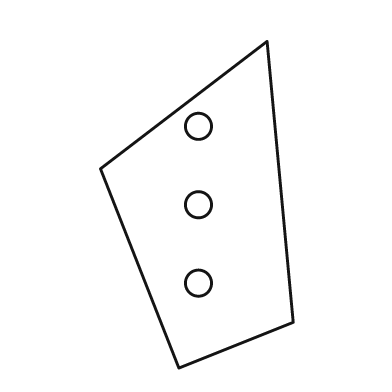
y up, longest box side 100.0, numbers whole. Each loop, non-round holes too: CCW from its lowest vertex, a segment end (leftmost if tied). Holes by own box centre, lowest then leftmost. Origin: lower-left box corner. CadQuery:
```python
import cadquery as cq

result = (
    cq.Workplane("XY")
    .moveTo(24.0, 0.0)
    .lineTo(59.0, 14.0)
    .lineTo(51.0, 100.0)
    .lineTo(0.0, 61.0)
    .close()
    .moveTo(30.0, 26.0)
    .circle(4.0)
    .moveTo(30.0, 50.0)
    .circle(4.0)
    .moveTo(30.0, 74.0)
    .circle(4.0)
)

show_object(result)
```